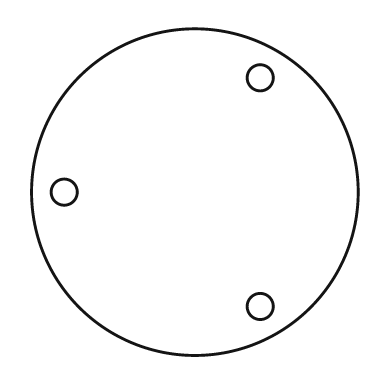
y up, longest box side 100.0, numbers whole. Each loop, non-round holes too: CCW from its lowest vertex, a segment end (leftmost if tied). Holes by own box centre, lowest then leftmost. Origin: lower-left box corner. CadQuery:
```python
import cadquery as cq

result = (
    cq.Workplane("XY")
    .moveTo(50.0, 50.0)
    .circle(50.0)
    .moveTo(70.0, 15.0)
    .circle(4.0)
    .moveTo(10.0, 50.0)
    .circle(4.0)
    .moveTo(70.0, 85.0)
    .circle(4.0)
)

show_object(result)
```